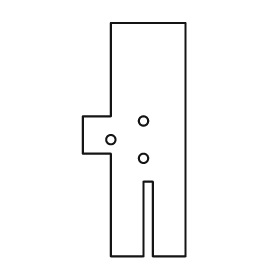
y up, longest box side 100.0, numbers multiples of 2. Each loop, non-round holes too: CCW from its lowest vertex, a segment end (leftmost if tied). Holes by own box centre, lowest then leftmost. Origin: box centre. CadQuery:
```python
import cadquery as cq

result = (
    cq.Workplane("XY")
    .moveTo(-10.0, -50.0)
    .lineTo(4.0, -50.0)
    .lineTo(4.0, -18.0)
    .lineTo(8.0, -18.0)
    .lineTo(8.0, -50.0)
    .lineTo(22.0, -50.0)
    .lineTo(22.0, 50.0)
    .lineTo(-10.0, 50.0)
    .lineTo(-10.0, 10.0)
    .lineTo(-22.0, 10.0)
    .lineTo(-22.0, -6.0)
    .lineTo(-10.0, -6.0)
    .close()
    .moveTo(4.0, -8.0)
    .circle(2.0)
    .moveTo(-10.0, 0.0)
    .circle(2.0)
    .moveTo(4.0, 8.0)
    .circle(2.0)
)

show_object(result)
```